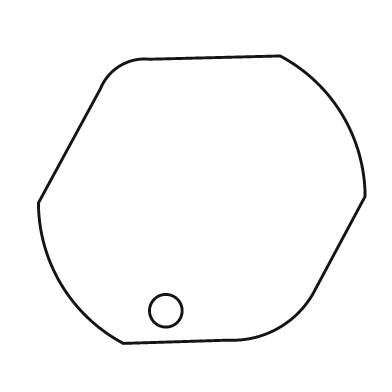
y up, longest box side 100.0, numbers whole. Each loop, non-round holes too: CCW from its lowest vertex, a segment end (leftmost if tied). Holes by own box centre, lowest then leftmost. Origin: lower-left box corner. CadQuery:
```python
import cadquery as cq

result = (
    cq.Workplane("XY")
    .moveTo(26.0, 0.0)
    .lineTo(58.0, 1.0)
    .threePointArc((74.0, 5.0), (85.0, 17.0))
    .lineTo(100.0, 45.0)
    .threePointArc((93.0, 70.0), (74.0, 88.0))
    .lineTo(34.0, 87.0)
    .threePointArc((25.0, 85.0), (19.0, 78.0))
    .lineTo(0.0, 43.0)
    .threePointArc((7.0, 18.0), (26.0, 0.0))
    .close()
    .moveTo(39.0, 10.0)
    .circle(5.0)
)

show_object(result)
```